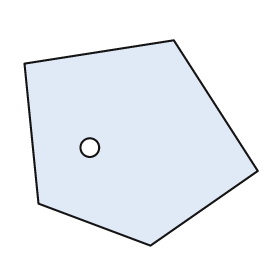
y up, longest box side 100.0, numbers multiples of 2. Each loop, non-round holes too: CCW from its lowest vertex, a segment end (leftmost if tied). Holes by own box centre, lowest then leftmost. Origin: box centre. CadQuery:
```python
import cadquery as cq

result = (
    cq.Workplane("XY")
    .moveTo(4.0, -44.0)
    .lineTo(50.0, -12.0)
    .lineTo(14.0, 44.0)
    .lineTo(-50.0, 34.0)
    .lineTo(-44.0, -26.0)
    .close()
    .moveTo(-22.0, -2.0)
    .circle(4.0)
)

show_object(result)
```